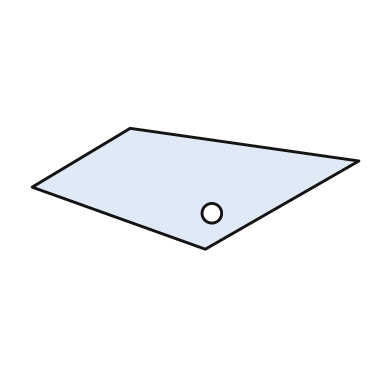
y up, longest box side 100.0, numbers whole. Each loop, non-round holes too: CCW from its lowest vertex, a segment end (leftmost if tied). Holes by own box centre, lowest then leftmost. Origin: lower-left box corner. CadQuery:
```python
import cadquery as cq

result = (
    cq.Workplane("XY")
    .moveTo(53.0, 0.0)
    .lineTo(100.0, 27.0)
    .lineTo(30.0, 37.0)
    .lineTo(0.0, 19.0)
    .close()
    .moveTo(55.0, 11.0)
    .circle(3.0)
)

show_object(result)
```